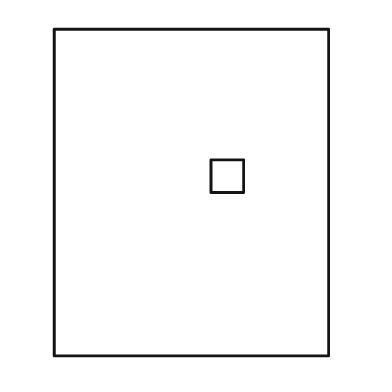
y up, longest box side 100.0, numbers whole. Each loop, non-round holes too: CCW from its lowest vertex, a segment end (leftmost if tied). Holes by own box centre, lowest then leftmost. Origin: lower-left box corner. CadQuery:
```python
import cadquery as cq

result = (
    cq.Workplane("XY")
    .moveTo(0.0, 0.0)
    .lineTo(84.0, 0.0)
    .lineTo(84.0, 100.0)
    .lineTo(0.0, 100.0)
    .close()
    .moveTo(48.0, 50.0)
    .lineTo(58.0, 50.0)
    .lineTo(58.0, 60.0)
    .lineTo(48.0, 60.0)
    .close()
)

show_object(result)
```